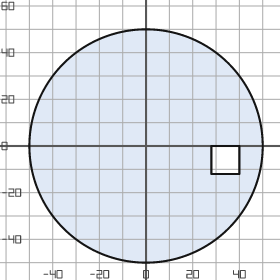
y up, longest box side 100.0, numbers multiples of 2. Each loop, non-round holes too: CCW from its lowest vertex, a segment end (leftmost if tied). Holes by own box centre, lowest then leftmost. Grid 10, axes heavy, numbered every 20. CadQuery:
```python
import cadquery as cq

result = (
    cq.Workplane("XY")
    .moveTo(0.0, 0.0)
    .circle(50.0)
    .moveTo(28.0, -12.0)
    .lineTo(40.0, -12.0)
    .lineTo(40.0, 0.0)
    .lineTo(28.0, 0.0)
    .close()
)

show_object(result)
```